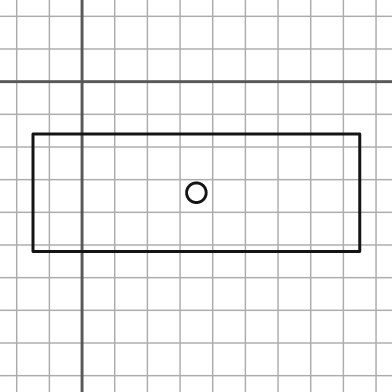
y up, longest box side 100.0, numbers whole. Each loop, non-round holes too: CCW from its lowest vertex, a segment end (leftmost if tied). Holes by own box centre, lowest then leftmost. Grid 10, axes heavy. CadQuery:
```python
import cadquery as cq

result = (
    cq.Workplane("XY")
    .moveTo(-15.0, -52.0)
    .lineTo(85.0, -52.0)
    .lineTo(85.0, -16.0)
    .lineTo(-15.0, -16.0)
    .close()
    .moveTo(35.0, -34.0)
    .circle(3.0)
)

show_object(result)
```